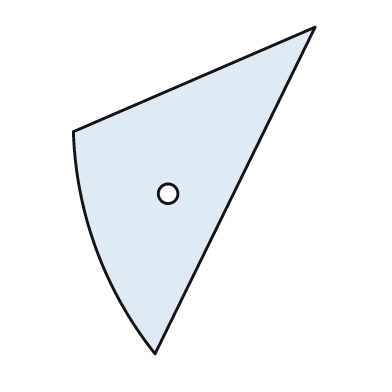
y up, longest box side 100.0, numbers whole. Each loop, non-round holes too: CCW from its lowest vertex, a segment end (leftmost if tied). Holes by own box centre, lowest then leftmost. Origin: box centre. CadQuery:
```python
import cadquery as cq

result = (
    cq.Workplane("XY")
    .moveTo(-12.0, -50.0)
    .lineTo(37.0, 50.0)
    .lineTo(-37.0, 18.0)
    .threePointArc((-30.0, -18.0), (-12.0, -50.0))
    .close()
    .moveTo(-8.0, -1.0)
    .circle(3.0)
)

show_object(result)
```